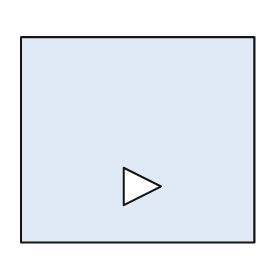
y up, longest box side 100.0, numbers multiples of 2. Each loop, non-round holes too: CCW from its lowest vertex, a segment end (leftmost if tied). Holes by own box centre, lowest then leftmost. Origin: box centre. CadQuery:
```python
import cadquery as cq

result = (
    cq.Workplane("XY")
    .moveTo(-50.0, -44.0)
    .lineTo(50.0, -44.0)
    .lineTo(50.0, 44.0)
    .lineTo(-50.0, 44.0)
    .close()
    .moveTo(-6.0, -28.0)
    .lineTo(10.0, -20.0)
    .lineTo(-6.0, -12.0)
    .close()
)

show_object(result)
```